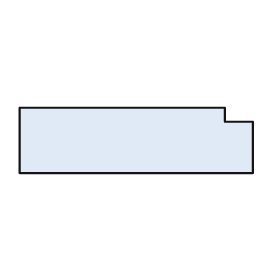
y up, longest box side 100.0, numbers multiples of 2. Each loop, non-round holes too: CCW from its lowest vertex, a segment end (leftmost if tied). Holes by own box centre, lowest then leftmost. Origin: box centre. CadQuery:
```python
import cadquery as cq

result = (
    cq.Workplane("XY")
    .moveTo(-50.0, -14.0)
    .lineTo(50.0, -14.0)
    .lineTo(50.0, 8.0)
    .lineTo(38.0, 8.0)
    .lineTo(38.0, 14.0)
    .lineTo(-50.0, 14.0)
    .close()
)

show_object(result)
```